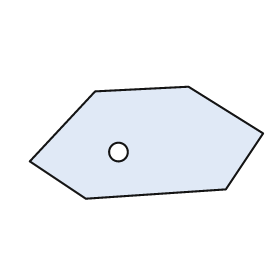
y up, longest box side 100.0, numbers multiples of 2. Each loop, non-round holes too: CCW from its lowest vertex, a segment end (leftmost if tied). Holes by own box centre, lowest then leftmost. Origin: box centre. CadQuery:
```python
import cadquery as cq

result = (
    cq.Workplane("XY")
    .moveTo(-26.0, -24.0)
    .lineTo(34.0, -20.0)
    .lineTo(50.0, 4.0)
    .lineTo(18.0, 24.0)
    .lineTo(-22.0, 22.0)
    .lineTo(-50.0, -8.0)
    .close()
    .moveTo(-12.0, -4.0)
    .circle(4.0)
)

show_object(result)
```